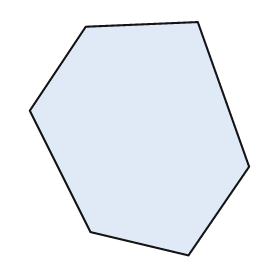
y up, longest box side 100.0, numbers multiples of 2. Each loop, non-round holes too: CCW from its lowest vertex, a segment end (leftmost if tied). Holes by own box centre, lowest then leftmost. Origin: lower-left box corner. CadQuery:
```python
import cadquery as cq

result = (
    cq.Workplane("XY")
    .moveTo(68.0, 0.0)
    .lineTo(94.0, 38.0)
    .lineTo(72.0, 100.0)
    .lineTo(24.0, 98.0)
    .lineTo(0.0, 62.0)
    .lineTo(26.0, 10.0)
    .close()
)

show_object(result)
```